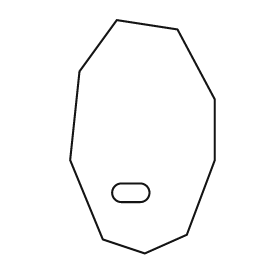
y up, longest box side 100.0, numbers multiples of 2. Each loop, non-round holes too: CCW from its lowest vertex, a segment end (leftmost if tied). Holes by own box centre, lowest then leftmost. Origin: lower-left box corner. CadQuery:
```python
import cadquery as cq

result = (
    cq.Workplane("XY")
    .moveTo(32.0, 0.0)
    .lineTo(50.0, 8.0)
    .lineTo(62.0, 40.0)
    .lineTo(62.0, 66.0)
    .lineTo(46.0, 96.0)
    .lineTo(20.0, 100.0)
    .lineTo(4.0, 78.0)
    .lineTo(0.0, 40.0)
    .lineTo(14.0, 6.0)
    .close()
    .moveTo(22.0, 22.0)
    .lineTo(30.0, 22.0)
    .threePointArc((34.0, 26.0), (30.0, 30.0))
    .lineTo(22.0, 30.0)
    .threePointArc((18.0, 26.0), (22.0, 22.0))
    .close()
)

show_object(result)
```